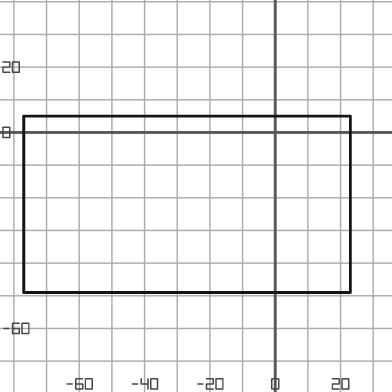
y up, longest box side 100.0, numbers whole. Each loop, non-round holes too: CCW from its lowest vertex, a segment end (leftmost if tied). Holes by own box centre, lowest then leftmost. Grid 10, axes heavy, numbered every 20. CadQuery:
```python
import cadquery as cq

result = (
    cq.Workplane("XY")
    .moveTo(-77.0, -49.0)
    .lineTo(23.0, -49.0)
    .lineTo(23.0, 5.0)
    .lineTo(-77.0, 5.0)
    .close()
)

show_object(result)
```